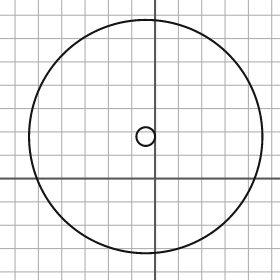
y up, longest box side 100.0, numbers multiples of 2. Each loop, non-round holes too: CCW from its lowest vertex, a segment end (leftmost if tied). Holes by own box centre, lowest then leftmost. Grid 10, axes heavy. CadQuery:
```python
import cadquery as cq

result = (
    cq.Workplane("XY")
    .moveTo(-4.0, 18.0)
    .circle(50.0)
    .moveTo(-4.0, 18.0)
    .circle(4.0)
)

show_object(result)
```